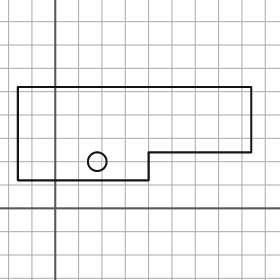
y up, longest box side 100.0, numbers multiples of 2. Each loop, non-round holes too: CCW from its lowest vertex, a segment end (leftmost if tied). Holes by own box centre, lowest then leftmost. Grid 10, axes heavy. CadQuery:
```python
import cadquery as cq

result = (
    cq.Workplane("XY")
    .moveTo(-16.0, 12.0)
    .lineTo(40.0, 12.0)
    .lineTo(40.0, 24.0)
    .lineTo(84.0, 24.0)
    .lineTo(84.0, 52.0)
    .lineTo(-16.0, 52.0)
    .close()
    .moveTo(18.0, 20.0)
    .circle(4.0)
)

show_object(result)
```